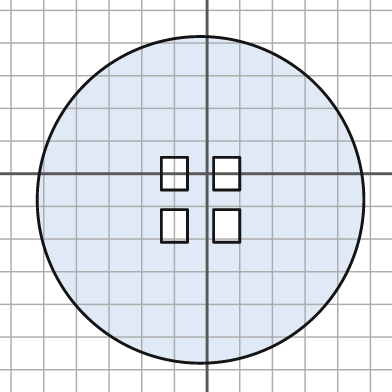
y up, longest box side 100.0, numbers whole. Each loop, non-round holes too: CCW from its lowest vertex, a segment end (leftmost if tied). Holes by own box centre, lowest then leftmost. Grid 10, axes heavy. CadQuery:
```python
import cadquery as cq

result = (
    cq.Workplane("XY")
    .moveTo(-2.0, -8.0)
    .circle(50.0)
    .moveTo(-14.0, -21.0)
    .lineTo(-6.0, -21.0)
    .lineTo(-6.0, -11.0)
    .lineTo(-14.0, -11.0)
    .close()
    .moveTo(2.0, -21.0)
    .lineTo(10.0, -21.0)
    .lineTo(10.0, -11.0)
    .lineTo(2.0, -11.0)
    .close()
    .moveTo(-14.0, -5.0)
    .lineTo(-6.0, -5.0)
    .lineTo(-6.0, 5.0)
    .lineTo(-14.0, 5.0)
    .close()
    .moveTo(2.0, -5.0)
    .lineTo(10.0, -5.0)
    .lineTo(10.0, 5.0)
    .lineTo(2.0, 5.0)
    .close()
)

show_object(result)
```